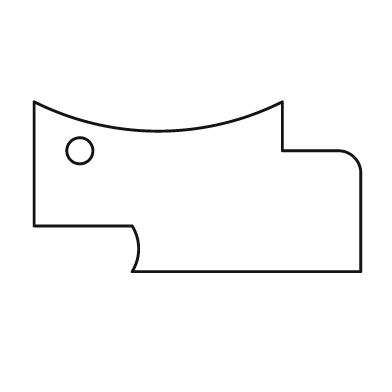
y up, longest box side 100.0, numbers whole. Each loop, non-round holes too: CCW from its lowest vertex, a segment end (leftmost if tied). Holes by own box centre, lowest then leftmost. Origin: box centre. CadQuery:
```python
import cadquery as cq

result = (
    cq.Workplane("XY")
    .moveTo(-20.0, -26.0)
    .lineTo(50.0, -26.0)
    .lineTo(50.0, 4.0)
    .threePointArc((48.0, 9.0), (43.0, 11.0))
    .lineTo(26.0, 11.0)
    .lineTo(26.0, 26.0)
    .threePointArc((-12.0, 17.0), (-50.0, 26.0))
    .lineTo(-50.0, -12.0)
    .lineTo(-20.0, -12.0)
    .threePointArc((-18.0, -19.0), (-20.0, -26.0))
    .close()
    .moveTo(-36.0, 11.0)
    .circle(4.0)
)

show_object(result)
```